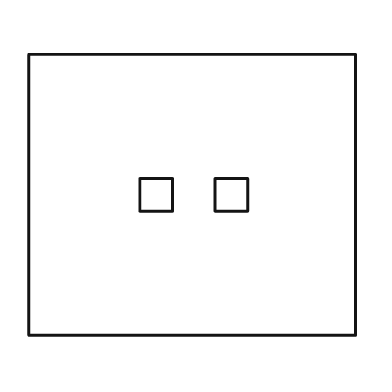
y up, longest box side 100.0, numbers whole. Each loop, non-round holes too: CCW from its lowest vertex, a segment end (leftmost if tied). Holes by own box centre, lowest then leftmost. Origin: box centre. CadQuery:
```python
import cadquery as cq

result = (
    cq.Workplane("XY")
    .moveTo(-50.0, -43.0)
    .lineTo(50.0, -43.0)
    .lineTo(50.0, 43.0)
    .lineTo(-50.0, 43.0)
    .close()
    .moveTo(-16.0, -5.0)
    .lineTo(-6.0, -5.0)
    .lineTo(-6.0, 5.0)
    .lineTo(-16.0, 5.0)
    .close()
    .moveTo(7.0, -5.0)
    .lineTo(17.0, -5.0)
    .lineTo(17.0, 5.0)
    .lineTo(7.0, 5.0)
    .close()
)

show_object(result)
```